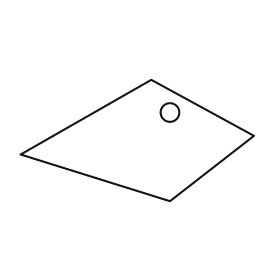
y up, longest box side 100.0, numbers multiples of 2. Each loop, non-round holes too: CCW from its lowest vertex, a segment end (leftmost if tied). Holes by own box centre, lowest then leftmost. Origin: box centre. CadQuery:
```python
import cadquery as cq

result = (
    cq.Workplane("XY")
    .moveTo(14.0, -26.0)
    .lineTo(50.0, 2.0)
    .lineTo(6.0, 26.0)
    .lineTo(-50.0, -6.0)
    .close()
    .moveTo(14.0, 12.0)
    .circle(4.0)
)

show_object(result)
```